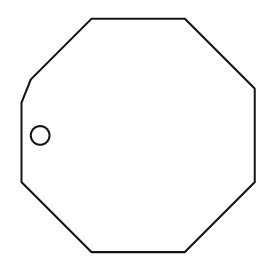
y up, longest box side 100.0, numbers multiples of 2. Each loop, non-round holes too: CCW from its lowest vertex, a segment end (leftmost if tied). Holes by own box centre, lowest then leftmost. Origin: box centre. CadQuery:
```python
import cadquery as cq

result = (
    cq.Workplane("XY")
    .moveTo(-20.0, -50.0)
    .lineTo(20.0, -50.0)
    .lineTo(50.0, -20.0)
    .lineTo(50.0, 20.0)
    .lineTo(20.0, 50.0)
    .lineTo(-20.0, 50.0)
    .lineTo(-46.0, 24.0)
    .lineTo(-50.0, 14.0)
    .lineTo(-50.0, -20.0)
    .close()
    .moveTo(-42.0, 0.0)
    .circle(4.0)
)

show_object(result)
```